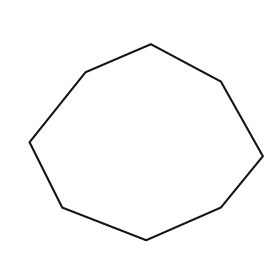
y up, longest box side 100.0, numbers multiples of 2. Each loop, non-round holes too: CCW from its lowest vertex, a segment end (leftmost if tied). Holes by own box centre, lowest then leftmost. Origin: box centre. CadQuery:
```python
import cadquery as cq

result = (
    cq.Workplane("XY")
    .moveTo(0.0, -42.0)
    .lineTo(32.0, -28.0)
    .lineTo(50.0, -6.0)
    .lineTo(32.0, 26.0)
    .lineTo(2.0, 42.0)
    .lineTo(-26.0, 30.0)
    .lineTo(-50.0, 0.0)
    .lineTo(-36.0, -28.0)
    .close()
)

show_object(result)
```